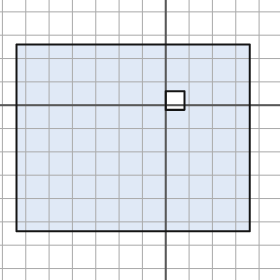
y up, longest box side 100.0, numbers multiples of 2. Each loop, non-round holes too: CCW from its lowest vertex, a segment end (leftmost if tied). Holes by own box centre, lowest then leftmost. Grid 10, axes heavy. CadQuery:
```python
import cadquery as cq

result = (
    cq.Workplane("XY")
    .moveTo(-64.0, -54.0)
    .lineTo(36.0, -54.0)
    .lineTo(36.0, 26.0)
    .lineTo(-64.0, 26.0)
    .close()
    .moveTo(0.0, -2.0)
    .lineTo(8.0, -2.0)
    .lineTo(8.0, 6.0)
    .lineTo(0.0, 6.0)
    .close()
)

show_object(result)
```